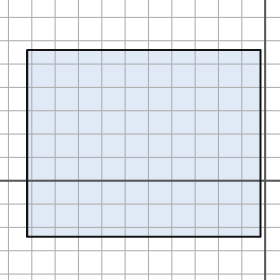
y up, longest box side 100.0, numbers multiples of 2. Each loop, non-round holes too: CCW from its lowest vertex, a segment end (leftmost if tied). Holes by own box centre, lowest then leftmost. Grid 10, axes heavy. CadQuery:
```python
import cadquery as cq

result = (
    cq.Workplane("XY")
    .moveTo(-102.0, -24.0)
    .lineTo(-2.0, -24.0)
    .lineTo(-2.0, 56.0)
    .lineTo(-102.0, 56.0)
    .close()
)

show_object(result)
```